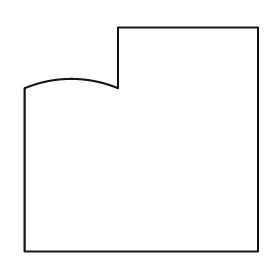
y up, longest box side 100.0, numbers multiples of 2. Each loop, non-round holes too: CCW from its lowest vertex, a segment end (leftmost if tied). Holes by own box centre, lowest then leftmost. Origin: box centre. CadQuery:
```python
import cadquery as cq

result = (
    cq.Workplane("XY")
    .moveTo(-50.0, -48.0)
    .lineTo(50.0, -48.0)
    .lineTo(50.0, 48.0)
    .lineTo(-10.0, 48.0)
    .lineTo(-10.0, 22.0)
    .threePointArc((-30.0, 26.0), (-50.0, 22.0))
    .close()
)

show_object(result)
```